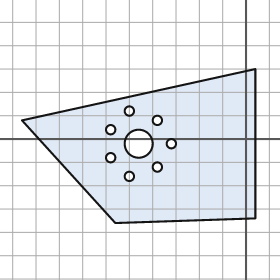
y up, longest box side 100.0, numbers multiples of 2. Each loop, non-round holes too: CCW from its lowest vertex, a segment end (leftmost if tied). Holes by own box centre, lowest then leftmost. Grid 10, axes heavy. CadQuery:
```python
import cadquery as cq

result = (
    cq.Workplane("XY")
    .moveTo(-56.0, -36.0)
    .lineTo(4.0, -34.0)
    .lineTo(4.0, 30.0)
    .lineTo(-96.0, 8.0)
    .close()
    .moveTo(-50.0, -16.0)
    .circle(2.0)
    .moveTo(-38.0, -12.0)
    .circle(2.0)
    .moveTo(-58.0, -8.0)
    .circle(2.0)
    .moveTo(-46.0, -2.0)
    .circle(6.0)
    .moveTo(-32.0, -2.0)
    .circle(2.0)
    .moveTo(-58.0, 4.0)
    .circle(2.0)
    .moveTo(-38.0, 8.0)
    .circle(2.0)
    .moveTo(-50.0, 12.0)
    .circle(2.0)
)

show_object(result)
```